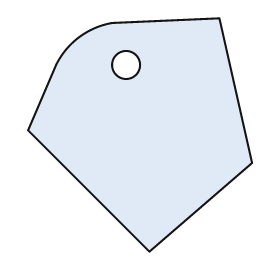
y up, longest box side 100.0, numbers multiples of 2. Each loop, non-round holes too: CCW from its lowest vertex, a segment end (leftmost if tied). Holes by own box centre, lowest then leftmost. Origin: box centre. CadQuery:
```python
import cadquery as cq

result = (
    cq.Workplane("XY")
    .moveTo(4.0, -50.0)
    .lineTo(48.0, -12.0)
    .lineTo(34.0, 50.0)
    .lineTo(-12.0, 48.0)
    .threePointArc((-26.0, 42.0), (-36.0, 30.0))
    .lineTo(-48.0, 2.0)
    .close()
    .moveTo(-6.0, 30.0)
    .circle(6.0)
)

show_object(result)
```